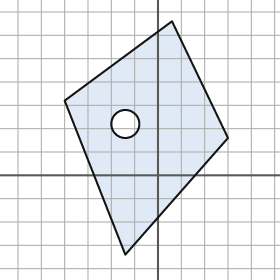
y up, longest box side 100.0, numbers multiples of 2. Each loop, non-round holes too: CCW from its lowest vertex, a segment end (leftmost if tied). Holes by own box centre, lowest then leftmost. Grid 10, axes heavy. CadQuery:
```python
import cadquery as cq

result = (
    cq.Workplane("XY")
    .moveTo(-14.0, -34.0)
    .lineTo(30.0, 16.0)
    .lineTo(6.0, 66.0)
    .lineTo(-40.0, 32.0)
    .close()
    .moveTo(-14.0, 22.0)
    .circle(6.0)
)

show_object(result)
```